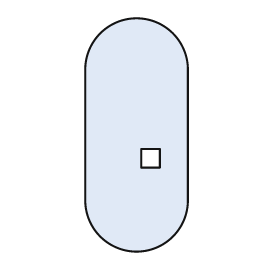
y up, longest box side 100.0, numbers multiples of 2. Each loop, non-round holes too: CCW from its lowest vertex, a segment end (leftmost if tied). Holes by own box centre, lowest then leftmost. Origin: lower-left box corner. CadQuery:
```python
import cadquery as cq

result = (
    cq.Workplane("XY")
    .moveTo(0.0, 22.0)
    .threePointArc((22.0, 0.0), (44.0, 22.0))
    .lineTo(44.0, 78.0)
    .threePointArc((22.0, 100.0), (0.0, 78.0))
    .close()
    .moveTo(24.0, 36.0)
    .lineTo(32.0, 36.0)
    .lineTo(32.0, 44.0)
    .lineTo(24.0, 44.0)
    .close()
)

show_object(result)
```